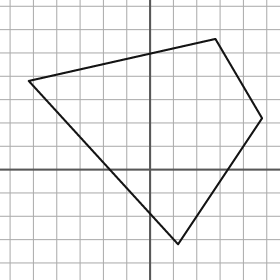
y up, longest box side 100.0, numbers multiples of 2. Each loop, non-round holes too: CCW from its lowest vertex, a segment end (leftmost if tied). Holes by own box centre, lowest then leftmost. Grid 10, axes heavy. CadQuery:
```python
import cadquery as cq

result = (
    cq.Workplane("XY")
    .moveTo(12.0, -32.0)
    .lineTo(48.0, 22.0)
    .lineTo(28.0, 56.0)
    .lineTo(-52.0, 38.0)
    .close()
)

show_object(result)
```